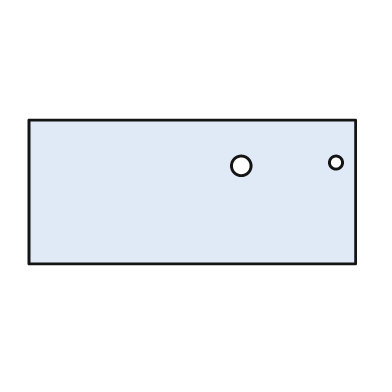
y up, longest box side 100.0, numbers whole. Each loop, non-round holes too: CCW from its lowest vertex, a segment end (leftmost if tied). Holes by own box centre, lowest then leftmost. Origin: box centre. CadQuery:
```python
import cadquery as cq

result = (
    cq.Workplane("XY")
    .moveTo(-50.0, -22.0)
    .lineTo(50.0, -22.0)
    .lineTo(50.0, 22.0)
    .lineTo(-50.0, 22.0)
    .close()
    .moveTo(15.0, 8.0)
    .circle(3.0)
    .moveTo(44.0, 9.0)
    .circle(2.0)
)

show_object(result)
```